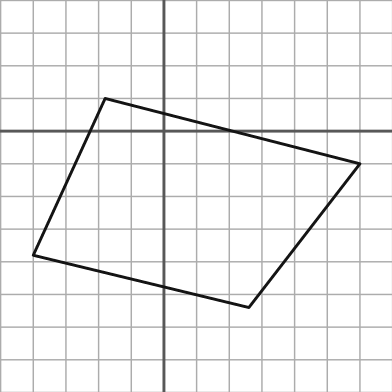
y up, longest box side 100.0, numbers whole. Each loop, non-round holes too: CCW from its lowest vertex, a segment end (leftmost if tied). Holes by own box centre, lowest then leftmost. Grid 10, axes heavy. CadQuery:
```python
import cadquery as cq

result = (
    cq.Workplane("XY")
    .moveTo(26.0, -54.0)
    .lineTo(60.0, -10.0)
    .lineTo(-18.0, 10.0)
    .lineTo(-40.0, -38.0)
    .close()
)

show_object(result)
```